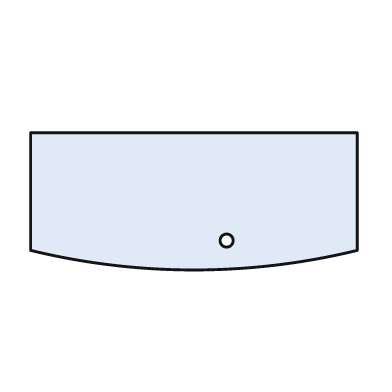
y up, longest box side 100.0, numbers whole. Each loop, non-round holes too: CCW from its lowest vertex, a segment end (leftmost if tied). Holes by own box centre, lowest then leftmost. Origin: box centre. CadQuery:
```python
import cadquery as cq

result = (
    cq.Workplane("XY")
    .moveTo(-50.0, -15.0)
    .threePointArc((0.0, -21.0), (50.0, -15.0))
    .lineTo(50.0, 21.0)
    .lineTo(-50.0, 21.0)
    .close()
    .moveTo(10.0, -12.0)
    .circle(2.0)
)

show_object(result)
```